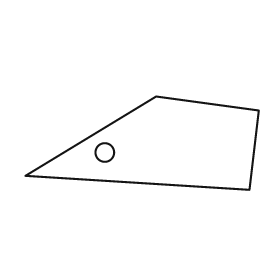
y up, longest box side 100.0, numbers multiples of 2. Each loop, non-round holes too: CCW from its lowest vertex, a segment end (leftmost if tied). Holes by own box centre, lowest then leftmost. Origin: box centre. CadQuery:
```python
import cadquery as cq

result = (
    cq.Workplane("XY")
    .moveTo(46.0, -20.0)
    .lineTo(50.0, 14.0)
    .lineTo(6.0, 20.0)
    .lineTo(-50.0, -14.0)
    .close()
    .moveTo(-16.0, -4.0)
    .circle(4.0)
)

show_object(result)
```